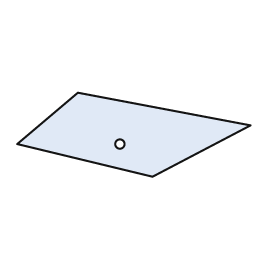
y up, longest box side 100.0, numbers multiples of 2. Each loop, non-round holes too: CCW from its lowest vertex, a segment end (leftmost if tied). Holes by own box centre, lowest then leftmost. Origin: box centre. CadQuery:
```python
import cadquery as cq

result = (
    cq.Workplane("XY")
    .moveTo(8.0, -18.0)
    .lineTo(50.0, 4.0)
    .lineTo(-24.0, 18.0)
    .lineTo(-50.0, -4.0)
    .close()
    .moveTo(-6.0, -4.0)
    .circle(2.0)
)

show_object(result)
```